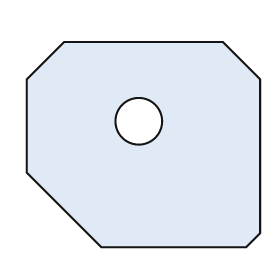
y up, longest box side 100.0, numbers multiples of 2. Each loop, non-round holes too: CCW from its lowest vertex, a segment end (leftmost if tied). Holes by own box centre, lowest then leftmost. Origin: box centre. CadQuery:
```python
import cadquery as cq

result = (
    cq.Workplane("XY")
    .moveTo(-18.0, -44.0)
    .lineTo(44.0, -44.0)
    .lineTo(50.0, -38.0)
    .lineTo(50.0, 28.0)
    .lineTo(34.0, 44.0)
    .lineTo(-34.0, 44.0)
    .lineTo(-50.0, 28.0)
    .lineTo(-50.0, -12.0)
    .close()
    .moveTo(-2.0, 10.0)
    .circle(10.0)
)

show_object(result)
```